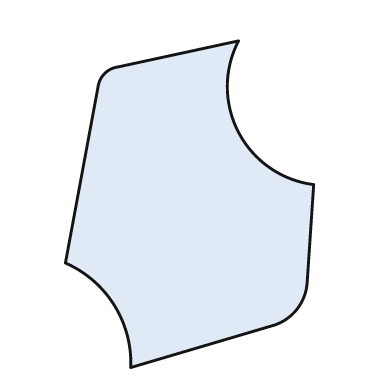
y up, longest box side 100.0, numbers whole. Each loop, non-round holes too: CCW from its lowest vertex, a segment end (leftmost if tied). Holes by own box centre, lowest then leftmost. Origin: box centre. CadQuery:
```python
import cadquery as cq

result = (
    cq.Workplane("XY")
    .moveTo(-18.0, -50.0)
    .lineTo(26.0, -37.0)
    .threePointArc((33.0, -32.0), (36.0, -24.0))
    .lineTo(38.0, 6.0)
    .threePointArc((15.0, 22.0), (15.0, 50.0))
    .lineTo(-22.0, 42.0)
    .threePointArc((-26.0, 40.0), (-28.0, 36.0))
    .lineTo(-38.0, -18.0)
    .threePointArc((-23.0, -31.0), (-18.0, -50.0))
    .close()
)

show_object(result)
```